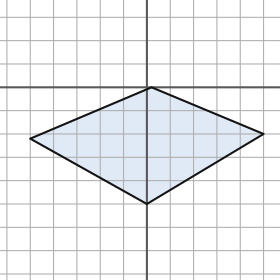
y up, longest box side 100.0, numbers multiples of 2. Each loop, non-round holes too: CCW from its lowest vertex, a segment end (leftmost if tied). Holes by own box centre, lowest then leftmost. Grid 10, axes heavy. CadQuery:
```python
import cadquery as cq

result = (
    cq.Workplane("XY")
    .moveTo(0.0, -50.0)
    .lineTo(50.0, -20.0)
    .lineTo(2.0, 0.0)
    .lineTo(-50.0, -22.0)
    .close()
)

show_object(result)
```